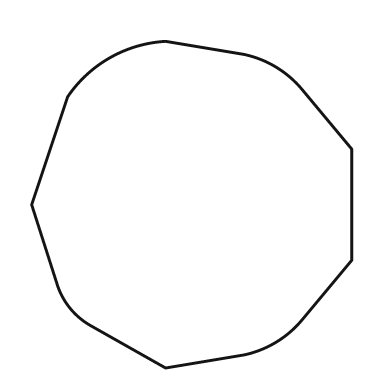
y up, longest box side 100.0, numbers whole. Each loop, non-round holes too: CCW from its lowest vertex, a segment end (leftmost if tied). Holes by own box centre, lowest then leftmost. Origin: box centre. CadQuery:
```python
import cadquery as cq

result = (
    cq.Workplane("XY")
    .moveTo(-8.0, -50.0)
    .lineTo(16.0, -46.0)
    .threePointArc((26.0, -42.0), (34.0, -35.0))
    .lineTo(49.0, -17.0)
    .lineTo(49.0, 17.0)
    .lineTo(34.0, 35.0)
    .threePointArc((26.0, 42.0), (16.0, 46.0))
    .lineTo(-8.0, 50.0)
    .threePointArc((-25.0, 45.0), (-38.0, 33.0))
    .lineTo(-49.0, 0.0)
    .lineTo(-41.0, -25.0)
    .threePointArc((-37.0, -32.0), (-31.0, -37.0))
    .close()
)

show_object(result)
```